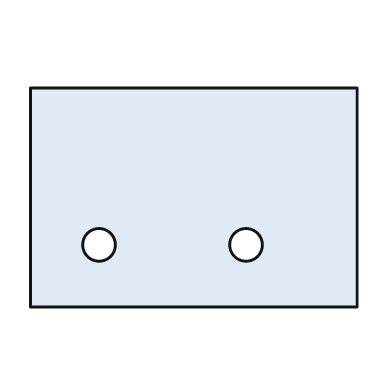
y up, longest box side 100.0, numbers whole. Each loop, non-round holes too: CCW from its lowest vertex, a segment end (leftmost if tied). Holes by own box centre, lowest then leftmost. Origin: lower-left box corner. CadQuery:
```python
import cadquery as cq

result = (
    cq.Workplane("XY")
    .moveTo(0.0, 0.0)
    .lineTo(100.0, 0.0)
    .lineTo(100.0, 67.0)
    .lineTo(0.0, 67.0)
    .close()
    .moveTo(21.0, 19.0)
    .circle(5.0)
    .moveTo(66.0, 19.0)
    .circle(5.0)
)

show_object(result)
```